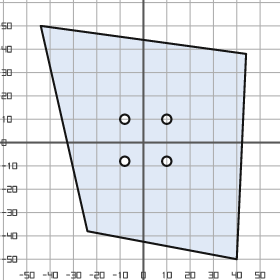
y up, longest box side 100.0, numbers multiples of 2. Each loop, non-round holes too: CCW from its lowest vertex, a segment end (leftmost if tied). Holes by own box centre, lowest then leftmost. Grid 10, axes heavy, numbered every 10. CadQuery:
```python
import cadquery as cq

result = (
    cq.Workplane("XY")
    .moveTo(40.0, -50.0)
    .lineTo(44.0, 38.0)
    .lineTo(-44.0, 50.0)
    .lineTo(-24.0, -38.0)
    .close()
    .moveTo(-8.0, -8.0)
    .circle(2.0)
    .moveTo(10.0, -8.0)
    .circle(2.0)
    .moveTo(-8.0, 10.0)
    .circle(2.0)
    .moveTo(10.0, 10.0)
    .circle(2.0)
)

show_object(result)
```